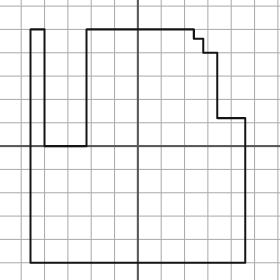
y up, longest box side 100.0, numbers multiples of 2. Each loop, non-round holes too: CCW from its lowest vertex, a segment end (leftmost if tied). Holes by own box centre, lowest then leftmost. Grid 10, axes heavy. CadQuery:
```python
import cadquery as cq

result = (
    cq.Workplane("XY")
    .moveTo(-46.0, -50.0)
    .lineTo(46.0, -50.0)
    .lineTo(46.0, 12.0)
    .lineTo(34.0, 12.0)
    .lineTo(34.0, 40.0)
    .lineTo(28.0, 40.0)
    .lineTo(28.0, 46.0)
    .lineTo(24.0, 46.0)
    .lineTo(24.0, 50.0)
    .lineTo(-22.0, 50.0)
    .lineTo(-22.0, 0.0)
    .lineTo(-40.0, 0.0)
    .lineTo(-40.0, 50.0)
    .lineTo(-46.0, 50.0)
    .close()
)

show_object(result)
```